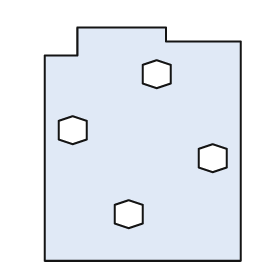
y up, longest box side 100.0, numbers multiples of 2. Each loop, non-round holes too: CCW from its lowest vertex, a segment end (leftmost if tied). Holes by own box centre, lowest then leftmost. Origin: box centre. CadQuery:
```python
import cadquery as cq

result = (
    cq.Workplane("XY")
    .moveTo(-42.0, -50.0)
    .lineTo(42.0, -50.0)
    .lineTo(42.0, 44.0)
    .lineTo(10.0, 44.0)
    .lineTo(10.0, 50.0)
    .lineTo(-28.0, 50.0)
    .lineTo(-28.0, 38.0)
    .lineTo(-42.0, 38.0)
    .close()
    .moveTo(-6.0, -36.0)
    .lineTo(0.0, -34.0)
    .lineTo(0.0, -26.0)
    .lineTo(-6.0, -24.0)
    .lineTo(-12.0, -26.0)
    .lineTo(-12.0, -34.0)
    .close()
    .moveTo(30.0, -12.0)
    .lineTo(36.0, -10.0)
    .lineTo(36.0, -2.0)
    .lineTo(30.0, 0.0)
    .lineTo(24.0, -2.0)
    .lineTo(24.0, -10.0)
    .close()
    .moveTo(-30.0, 0.0)
    .lineTo(-24.0, 2.0)
    .lineTo(-24.0, 10.0)
    .lineTo(-30.0, 12.0)
    .lineTo(-36.0, 10.0)
    .lineTo(-36.0, 2.0)
    .close()
    .moveTo(6.0, 24.0)
    .lineTo(12.0, 26.0)
    .lineTo(12.0, 34.0)
    .lineTo(6.0, 36.0)
    .lineTo(0.0, 34.0)
    .lineTo(0.0, 26.0)
    .close()
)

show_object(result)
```